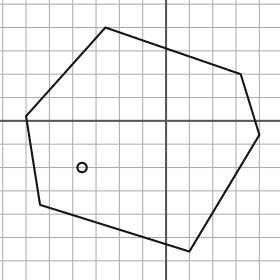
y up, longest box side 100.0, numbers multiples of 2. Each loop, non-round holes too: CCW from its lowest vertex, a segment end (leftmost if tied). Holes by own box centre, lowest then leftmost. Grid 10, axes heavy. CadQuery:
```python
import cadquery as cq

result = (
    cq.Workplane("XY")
    .moveTo(10.0, -56.0)
    .lineTo(40.0, -6.0)
    .lineTo(32.0, 20.0)
    .lineTo(-26.0, 40.0)
    .lineTo(-60.0, 2.0)
    .lineTo(-54.0, -36.0)
    .close()
    .moveTo(-36.0, -20.0)
    .circle(2.0)
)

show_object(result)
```